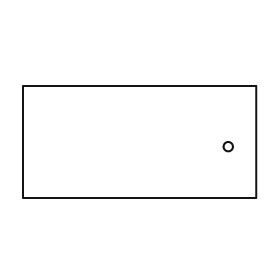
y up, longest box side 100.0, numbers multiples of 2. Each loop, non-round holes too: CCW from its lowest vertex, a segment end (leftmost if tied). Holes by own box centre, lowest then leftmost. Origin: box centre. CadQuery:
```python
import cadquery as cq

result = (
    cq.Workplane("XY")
    .moveTo(-50.0, -24.0)
    .lineTo(50.0, -24.0)
    .lineTo(50.0, 24.0)
    .lineTo(-50.0, 24.0)
    .close()
    .moveTo(38.0, -2.0)
    .circle(2.0)
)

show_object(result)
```